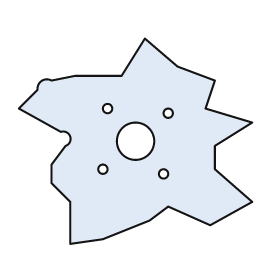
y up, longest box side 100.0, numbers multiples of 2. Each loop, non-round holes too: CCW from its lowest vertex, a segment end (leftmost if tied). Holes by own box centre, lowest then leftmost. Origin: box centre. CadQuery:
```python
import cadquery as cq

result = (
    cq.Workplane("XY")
    .moveTo(-28.0, -44.0)
    .lineTo(-14.0, -42.0)
    .lineTo(6.0, -34.0)
    .lineTo(14.0, -28.0)
    .lineTo(32.0, -36.0)
    .lineTo(50.0, -26.0)
    .lineTo(34.0, -12.0)
    .lineTo(34.0, -2.0)
    .lineTo(50.0, 8.0)
    .lineTo(30.0, 14.0)
    .lineTo(34.0, 26.0)
    .lineTo(18.0, 32.0)
    .lineTo(4.0, 44.0)
    .lineTo(-6.0, 28.0)
    .lineTo(-26.0, 28.0)
    .lineTo(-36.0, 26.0)
    .threePointArc((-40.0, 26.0), (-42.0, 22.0))
    .lineTo(-50.0, 14.0)
    .lineTo(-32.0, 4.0)
    .threePointArc((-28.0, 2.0), (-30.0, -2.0))
    .lineTo(-36.0, -10.0)
    .lineTo(-36.0, -18.0)
    .lineTo(-28.0, -26.0)
    .close()
    .moveTo(12.0, -14.0)
    .circle(2.0)
    .moveTo(-14.0, -12.0)
    .circle(2.0)
    .moveTo(0.0, 0.0)
    .circle(8.0)
    .moveTo(14.0, 12.0)
    .circle(2.0)
    .moveTo(-12.0, 14.0)
    .circle(2.0)
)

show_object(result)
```